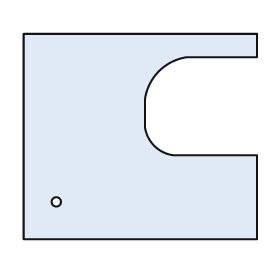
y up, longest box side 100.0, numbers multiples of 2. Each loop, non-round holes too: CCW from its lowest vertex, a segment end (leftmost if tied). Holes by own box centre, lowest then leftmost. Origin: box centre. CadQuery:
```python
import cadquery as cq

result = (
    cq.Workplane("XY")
    .moveTo(-50.0, -44.0)
    .lineTo(50.0, -44.0)
    .lineTo(50.0, -8.0)
    .lineTo(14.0, -8.0)
    .threePointArc((6.0, -4.0), (2.0, 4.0))
    .lineTo(2.0, 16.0)
    .threePointArc((8.0, 28.0), (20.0, 34.0))
    .lineTo(50.0, 34.0)
    .lineTo(50.0, 44.0)
    .lineTo(-50.0, 44.0)
    .close()
    .moveTo(-36.0, -28.0)
    .circle(2.0)
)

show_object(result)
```